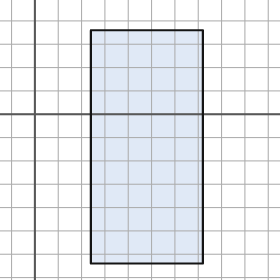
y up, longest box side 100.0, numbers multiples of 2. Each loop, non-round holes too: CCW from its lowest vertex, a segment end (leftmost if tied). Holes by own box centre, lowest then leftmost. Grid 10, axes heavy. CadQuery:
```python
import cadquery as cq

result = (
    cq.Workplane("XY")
    .moveTo(24.0, -64.0)
    .lineTo(72.0, -64.0)
    .lineTo(72.0, 36.0)
    .lineTo(24.0, 36.0)
    .close()
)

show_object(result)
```